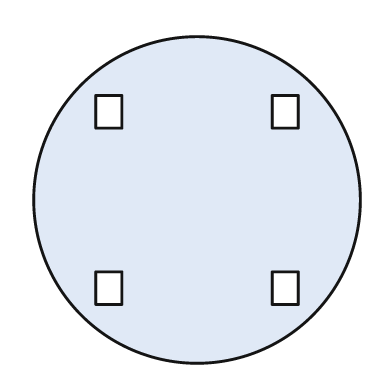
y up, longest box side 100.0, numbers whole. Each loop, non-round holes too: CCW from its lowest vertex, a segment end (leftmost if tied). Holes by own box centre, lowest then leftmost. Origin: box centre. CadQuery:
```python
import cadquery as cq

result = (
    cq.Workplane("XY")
    .moveTo(0.0, 0.0)
    .circle(50.0)
    .moveTo(-31.0, -32.0)
    .lineTo(-23.0, -32.0)
    .lineTo(-23.0, -22.0)
    .lineTo(-31.0, -22.0)
    .close()
    .moveTo(23.0, -32.0)
    .lineTo(31.0, -32.0)
    .lineTo(31.0, -22.0)
    .lineTo(23.0, -22.0)
    .close()
    .moveTo(-31.0, 22.0)
    .lineTo(-23.0, 22.0)
    .lineTo(-23.0, 32.0)
    .lineTo(-31.0, 32.0)
    .close()
    .moveTo(23.0, 22.0)
    .lineTo(31.0, 22.0)
    .lineTo(31.0, 32.0)
    .lineTo(23.0, 32.0)
    .close()
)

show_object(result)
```